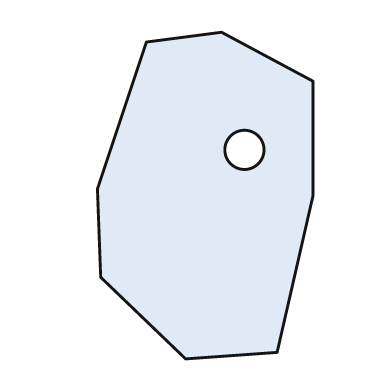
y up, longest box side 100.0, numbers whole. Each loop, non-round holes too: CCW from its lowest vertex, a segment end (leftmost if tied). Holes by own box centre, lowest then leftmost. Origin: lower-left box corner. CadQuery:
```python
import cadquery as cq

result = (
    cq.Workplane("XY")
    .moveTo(27.0, 0.0)
    .lineTo(55.0, 2.0)
    .lineTo(66.0, 50.0)
    .lineTo(66.0, 85.0)
    .lineTo(38.0, 100.0)
    .lineTo(15.0, 97.0)
    .lineTo(0.0, 52.0)
    .lineTo(1.0, 25.0)
    .close()
    .moveTo(45.0, 64.0)
    .circle(6.0)
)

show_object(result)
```